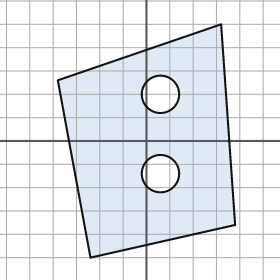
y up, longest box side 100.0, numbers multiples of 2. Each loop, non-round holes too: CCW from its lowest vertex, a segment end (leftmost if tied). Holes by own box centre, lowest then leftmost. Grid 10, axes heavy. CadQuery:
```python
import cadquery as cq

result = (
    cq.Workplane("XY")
    .moveTo(-24.0, -50.0)
    .lineTo(38.0, -36.0)
    .lineTo(32.0, 50.0)
    .lineTo(-38.0, 26.0)
    .close()
    .moveTo(6.0, -14.0)
    .circle(8.0)
    .moveTo(6.0, 20.0)
    .circle(8.0)
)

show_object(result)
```